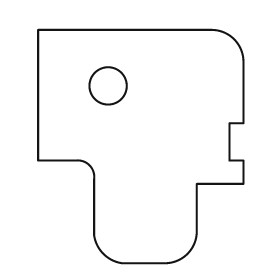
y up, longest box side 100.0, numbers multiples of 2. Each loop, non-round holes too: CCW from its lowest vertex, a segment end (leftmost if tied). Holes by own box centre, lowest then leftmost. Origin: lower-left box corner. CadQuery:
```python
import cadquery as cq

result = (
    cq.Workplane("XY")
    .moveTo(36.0, 0.0)
    .lineTo(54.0, 0.0)
    .threePointArc((64.0, 4.0), (68.0, 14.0))
    .lineTo(68.0, 34.0)
    .lineTo(88.0, 34.0)
    .lineTo(88.0, 44.0)
    .lineTo(82.0, 44.0)
    .lineTo(82.0, 60.0)
    .lineTo(88.0, 60.0)
    .lineTo(88.0, 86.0)
    .threePointArc((84.0, 96.0), (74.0, 100.0))
    .lineTo(0.0, 100.0)
    .lineTo(0.0, 44.0)
    .lineTo(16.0, 44.0)
    .threePointArc((22.0, 42.0), (24.0, 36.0))
    .lineTo(24.0, 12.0)
    .threePointArc((28.0, 4.0), (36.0, 0.0))
    .close()
    .moveTo(30.0, 76.0)
    .circle(8.0)
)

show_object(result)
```